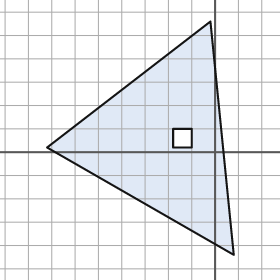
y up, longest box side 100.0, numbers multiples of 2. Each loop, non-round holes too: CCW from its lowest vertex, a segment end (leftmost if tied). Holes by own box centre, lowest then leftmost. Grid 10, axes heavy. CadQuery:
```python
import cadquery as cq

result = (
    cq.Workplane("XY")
    .moveTo(8.0, -44.0)
    .lineTo(-2.0, 56.0)
    .lineTo(-72.0, 2.0)
    .close()
    .moveTo(-18.0, 2.0)
    .lineTo(-10.0, 2.0)
    .lineTo(-10.0, 10.0)
    .lineTo(-18.0, 10.0)
    .close()
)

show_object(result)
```